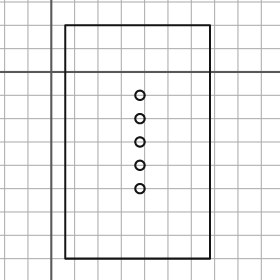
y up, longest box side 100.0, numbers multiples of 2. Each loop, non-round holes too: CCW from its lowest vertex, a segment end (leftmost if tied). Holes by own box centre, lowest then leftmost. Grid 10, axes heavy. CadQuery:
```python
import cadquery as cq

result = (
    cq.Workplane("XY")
    .moveTo(6.0, -80.0)
    .lineTo(68.0, -80.0)
    .lineTo(68.0, 20.0)
    .lineTo(6.0, 20.0)
    .close()
    .moveTo(38.0, -50.0)
    .circle(2.0)
    .moveTo(38.0, -40.0)
    .circle(2.0)
    .moveTo(38.0, -30.0)
    .circle(2.0)
    .moveTo(38.0, -20.0)
    .circle(2.0)
    .moveTo(38.0, -10.0)
    .circle(2.0)
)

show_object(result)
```